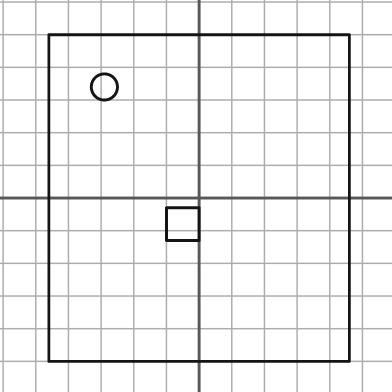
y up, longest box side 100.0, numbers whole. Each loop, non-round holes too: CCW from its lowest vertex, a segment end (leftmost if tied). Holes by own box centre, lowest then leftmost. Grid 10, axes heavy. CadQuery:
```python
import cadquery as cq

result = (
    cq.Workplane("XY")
    .moveTo(-46.0, -50.0)
    .lineTo(46.0, -50.0)
    .lineTo(46.0, 50.0)
    .lineTo(-46.0, 50.0)
    .close()
    .moveTo(-10.0, -13.0)
    .lineTo(0.0, -13.0)
    .lineTo(0.0, -3.0)
    .lineTo(-10.0, -3.0)
    .close()
    .moveTo(-29.0, 34.0)
    .circle(4.0)
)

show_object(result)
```